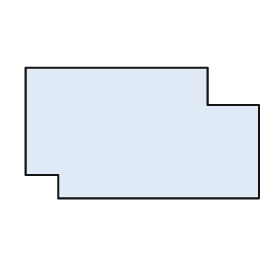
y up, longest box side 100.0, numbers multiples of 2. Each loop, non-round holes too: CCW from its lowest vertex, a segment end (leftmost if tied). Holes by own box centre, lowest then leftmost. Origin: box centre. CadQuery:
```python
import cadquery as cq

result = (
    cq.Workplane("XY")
    .moveTo(-36.0, -28.0)
    .lineTo(50.0, -28.0)
    .lineTo(50.0, 12.0)
    .lineTo(28.0, 12.0)
    .lineTo(28.0, 28.0)
    .lineTo(-50.0, 28.0)
    .lineTo(-50.0, -18.0)
    .lineTo(-36.0, -18.0)
    .close()
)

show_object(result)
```